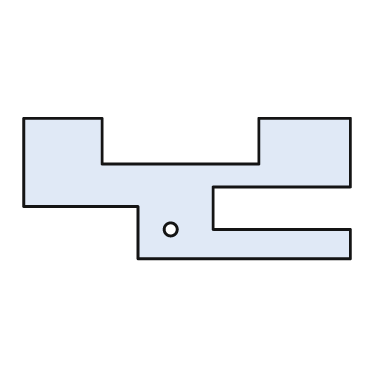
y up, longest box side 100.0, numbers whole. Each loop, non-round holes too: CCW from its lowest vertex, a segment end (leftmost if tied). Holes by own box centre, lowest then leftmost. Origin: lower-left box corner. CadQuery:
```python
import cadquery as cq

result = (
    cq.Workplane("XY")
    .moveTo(35.0, 0.0)
    .lineTo(100.0, 0.0)
    .lineTo(100.0, 9.0)
    .lineTo(58.0, 9.0)
    .lineTo(58.0, 22.0)
    .lineTo(100.0, 22.0)
    .lineTo(100.0, 43.0)
    .lineTo(72.0, 43.0)
    .lineTo(72.0, 29.0)
    .lineTo(24.0, 29.0)
    .lineTo(24.0, 43.0)
    .lineTo(0.0, 43.0)
    .lineTo(0.0, 16.0)
    .lineTo(35.0, 16.0)
    .close()
    .moveTo(45.0, 9.0)
    .circle(2.0)
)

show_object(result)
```